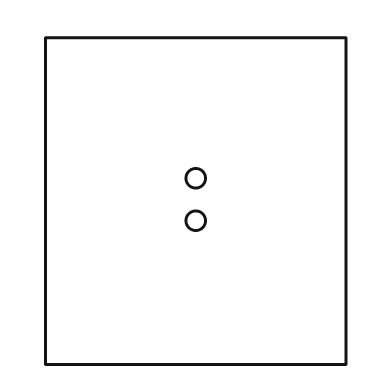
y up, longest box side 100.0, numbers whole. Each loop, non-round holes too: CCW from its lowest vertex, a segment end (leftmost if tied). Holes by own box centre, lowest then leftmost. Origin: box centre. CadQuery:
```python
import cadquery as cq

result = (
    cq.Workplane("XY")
    .moveTo(-46.0, -50.0)
    .lineTo(46.0, -50.0)
    .lineTo(46.0, 50.0)
    .lineTo(-46.0, 50.0)
    .close()
    .moveTo(0.0, -6.0)
    .circle(3.0)
    .moveTo(0.0, 7.0)
    .circle(3.0)
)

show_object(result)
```